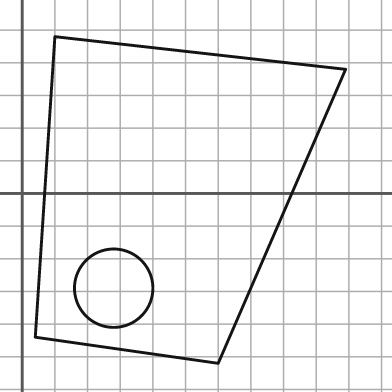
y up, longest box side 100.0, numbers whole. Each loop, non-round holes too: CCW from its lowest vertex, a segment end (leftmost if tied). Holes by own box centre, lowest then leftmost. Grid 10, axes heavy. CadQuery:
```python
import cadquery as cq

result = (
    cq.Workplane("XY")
    .moveTo(60.0, -52.0)
    .lineTo(99.0, 38.0)
    .lineTo(10.0, 48.0)
    .lineTo(4.0, -44.0)
    .close()
    .moveTo(28.0, -29.0)
    .circle(12.0)
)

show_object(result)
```